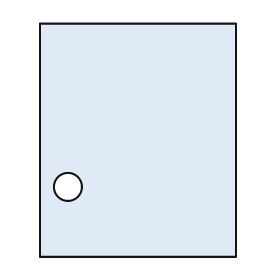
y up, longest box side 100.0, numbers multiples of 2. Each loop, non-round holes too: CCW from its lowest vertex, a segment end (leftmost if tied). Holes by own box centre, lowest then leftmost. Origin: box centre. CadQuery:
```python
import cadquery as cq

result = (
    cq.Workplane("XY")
    .moveTo(-42.0, -50.0)
    .lineTo(42.0, -50.0)
    .lineTo(42.0, 50.0)
    .lineTo(-42.0, 50.0)
    .close()
    .moveTo(-30.0, -20.0)
    .circle(6.0)
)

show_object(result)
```